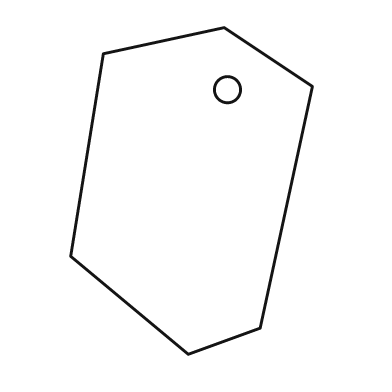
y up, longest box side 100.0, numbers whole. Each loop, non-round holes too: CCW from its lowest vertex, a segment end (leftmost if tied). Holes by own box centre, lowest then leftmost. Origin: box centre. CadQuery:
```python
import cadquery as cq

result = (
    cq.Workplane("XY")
    .moveTo(-1.0, -50.0)
    .lineTo(21.0, -42.0)
    .lineTo(37.0, 32.0)
    .lineTo(10.0, 50.0)
    .lineTo(-27.0, 42.0)
    .lineTo(-37.0, -20.0)
    .close()
    .moveTo(11.0, 31.0)
    .circle(4.0)
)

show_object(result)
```